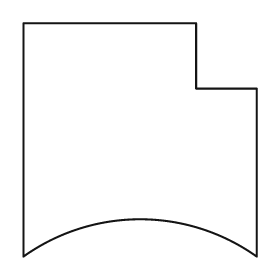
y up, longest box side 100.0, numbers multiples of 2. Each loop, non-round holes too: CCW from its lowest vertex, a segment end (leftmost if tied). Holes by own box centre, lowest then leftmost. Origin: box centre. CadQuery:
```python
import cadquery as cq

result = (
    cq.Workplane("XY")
    .moveTo(-50.0, -50.0)
    .threePointArc((0.0, -34.0), (50.0, -50.0))
    .lineTo(50.0, 22.0)
    .lineTo(24.0, 22.0)
    .lineTo(24.0, 50.0)
    .lineTo(-50.0, 50.0)
    .close()
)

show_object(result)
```